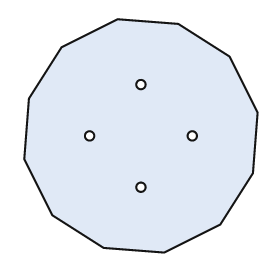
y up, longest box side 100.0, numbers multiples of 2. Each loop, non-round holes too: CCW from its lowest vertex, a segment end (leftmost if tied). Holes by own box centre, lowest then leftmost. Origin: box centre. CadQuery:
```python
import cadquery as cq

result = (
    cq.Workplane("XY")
    .moveTo(10.0, -50.0)
    .lineTo(34.0, -38.0)
    .lineTo(48.0, -16.0)
    .lineTo(50.0, 10.0)
    .lineTo(38.0, 34.0)
    .lineTo(16.0, 48.0)
    .lineTo(-10.0, 50.0)
    .lineTo(-34.0, 38.0)
    .lineTo(-48.0, 16.0)
    .lineTo(-50.0, -10.0)
    .lineTo(-38.0, -34.0)
    .lineTo(-16.0, -48.0)
    .close()
    .moveTo(0.0, -22.0)
    .circle(2.0)
    .moveTo(-22.0, 0.0)
    .circle(2.0)
    .moveTo(22.0, 0.0)
    .circle(2.0)
    .moveTo(0.0, 22.0)
    .circle(2.0)
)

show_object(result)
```